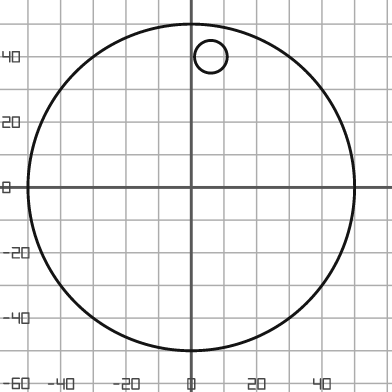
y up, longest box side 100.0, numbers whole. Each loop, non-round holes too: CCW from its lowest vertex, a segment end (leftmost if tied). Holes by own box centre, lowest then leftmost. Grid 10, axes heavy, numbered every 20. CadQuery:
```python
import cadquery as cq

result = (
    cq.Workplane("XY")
    .moveTo(0.0, 0.0)
    .circle(50.0)
    .moveTo(6.0, 40.0)
    .circle(5.0)
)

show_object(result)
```